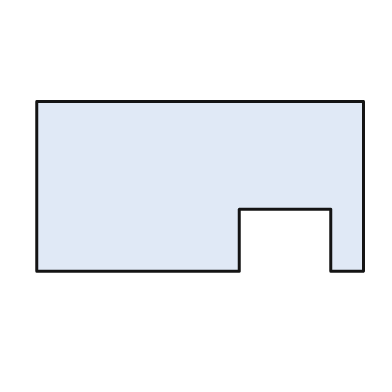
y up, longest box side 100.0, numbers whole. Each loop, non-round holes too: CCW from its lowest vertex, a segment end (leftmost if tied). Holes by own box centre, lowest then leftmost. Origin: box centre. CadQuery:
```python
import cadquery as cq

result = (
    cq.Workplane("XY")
    .moveTo(-50.0, -26.0)
    .lineTo(12.0, -26.0)
    .lineTo(12.0, -7.0)
    .lineTo(40.0, -7.0)
    .lineTo(40.0, -26.0)
    .lineTo(50.0, -26.0)
    .lineTo(50.0, 26.0)
    .lineTo(-50.0, 26.0)
    .close()
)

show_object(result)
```